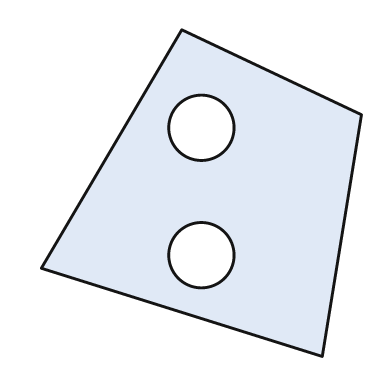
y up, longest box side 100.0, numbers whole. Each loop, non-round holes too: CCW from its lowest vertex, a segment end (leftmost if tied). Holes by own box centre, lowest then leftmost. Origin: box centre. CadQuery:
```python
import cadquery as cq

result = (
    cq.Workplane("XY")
    .moveTo(37.0, -50.0)
    .lineTo(49.0, 24.0)
    .lineTo(-6.0, 50.0)
    .lineTo(-49.0, -23.0)
    .close()
    .moveTo(0.0, -19.0)
    .circle(10.0)
    .moveTo(0.0, 20.0)
    .circle(10.0)
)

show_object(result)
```